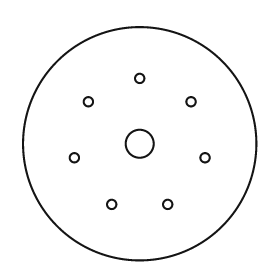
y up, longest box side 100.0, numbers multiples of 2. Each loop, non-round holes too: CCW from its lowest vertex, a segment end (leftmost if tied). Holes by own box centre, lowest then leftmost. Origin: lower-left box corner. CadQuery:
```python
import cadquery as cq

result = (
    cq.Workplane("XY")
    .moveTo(50.0, 50.0)
    .circle(50.0)
    .moveTo(38.0, 24.0)
    .circle(2.0)
    .moveTo(62.0, 24.0)
    .circle(2.0)
    .moveTo(22.0, 44.0)
    .circle(2.0)
    .moveTo(78.0, 44.0)
    .circle(2.0)
    .moveTo(50.0, 50.0)
    .circle(6.0)
    .moveTo(28.0, 68.0)
    .circle(2.0)
    .moveTo(72.0, 68.0)
    .circle(2.0)
    .moveTo(50.0, 78.0)
    .circle(2.0)
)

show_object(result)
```